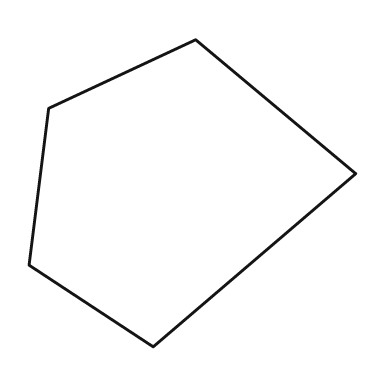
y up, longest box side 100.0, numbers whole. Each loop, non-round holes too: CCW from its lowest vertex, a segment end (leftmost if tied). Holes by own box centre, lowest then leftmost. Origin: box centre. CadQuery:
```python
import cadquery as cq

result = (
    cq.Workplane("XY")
    .moveTo(-12.0, -47.0)
    .lineTo(50.0, 6.0)
    .lineTo(1.0, 47.0)
    .lineTo(-44.0, 26.0)
    .lineTo(-50.0, -22.0)
    .close()
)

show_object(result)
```